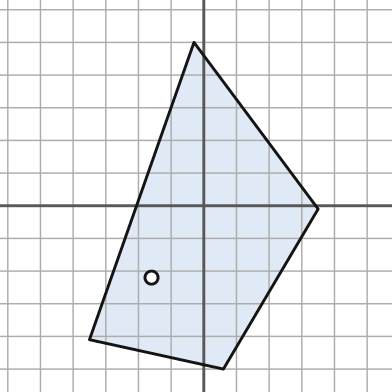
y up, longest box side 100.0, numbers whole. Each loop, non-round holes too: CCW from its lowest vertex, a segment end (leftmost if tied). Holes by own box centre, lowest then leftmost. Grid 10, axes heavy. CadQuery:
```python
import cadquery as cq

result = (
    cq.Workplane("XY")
    .moveTo(6.0, -50.0)
    .lineTo(35.0, -1.0)
    .lineTo(-3.0, 50.0)
    .lineTo(-35.0, -41.0)
    .close()
    .moveTo(-16.0, -22.0)
    .circle(2.0)
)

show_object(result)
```